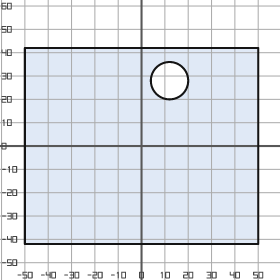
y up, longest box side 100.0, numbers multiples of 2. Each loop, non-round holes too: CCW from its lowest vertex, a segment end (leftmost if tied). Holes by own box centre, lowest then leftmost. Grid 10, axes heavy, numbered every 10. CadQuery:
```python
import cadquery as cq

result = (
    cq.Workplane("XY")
    .moveTo(-50.0, -42.0)
    .lineTo(50.0, -42.0)
    .lineTo(50.0, 42.0)
    .lineTo(-50.0, 42.0)
    .close()
    .moveTo(12.0, 28.0)
    .circle(8.0)
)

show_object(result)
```